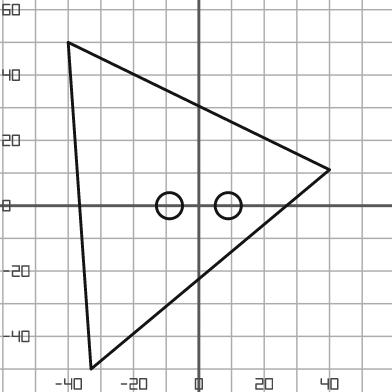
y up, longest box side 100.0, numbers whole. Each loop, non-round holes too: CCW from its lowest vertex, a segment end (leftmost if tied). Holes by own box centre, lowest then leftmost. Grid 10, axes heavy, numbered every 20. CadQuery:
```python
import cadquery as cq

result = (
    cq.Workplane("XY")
    .moveTo(-33.0, -50.0)
    .lineTo(40.0, 11.0)
    .lineTo(-40.0, 50.0)
    .close()
    .moveTo(-9.0, 0.0)
    .circle(4.0)
    .moveTo(9.0, 0.0)
    .circle(4.0)
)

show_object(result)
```